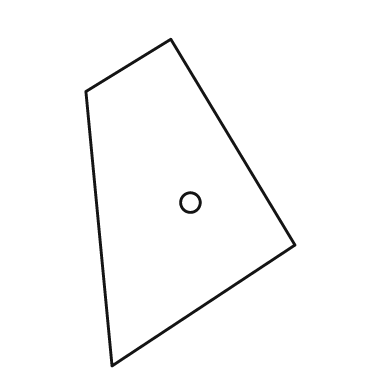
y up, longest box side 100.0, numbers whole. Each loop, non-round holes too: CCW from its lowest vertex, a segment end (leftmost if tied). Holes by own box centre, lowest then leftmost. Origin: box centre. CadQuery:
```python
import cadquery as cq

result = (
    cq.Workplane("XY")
    .moveTo(-24.0, -50.0)
    .lineTo(32.0, -13.0)
    .lineTo(-6.0, 50.0)
    .lineTo(-32.0, 34.0)
    .close()
    .moveTo(0.0, 0.0)
    .circle(3.0)
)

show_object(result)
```